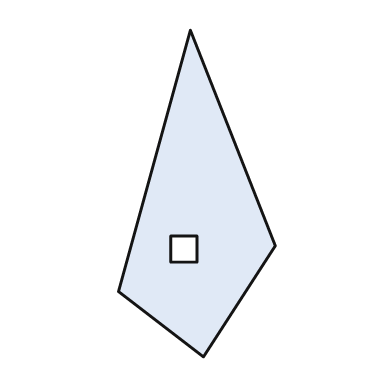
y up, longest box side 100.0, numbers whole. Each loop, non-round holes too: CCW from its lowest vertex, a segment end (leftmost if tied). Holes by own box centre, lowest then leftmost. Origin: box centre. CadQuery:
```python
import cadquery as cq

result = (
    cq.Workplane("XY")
    .moveTo(2.0, -50.0)
    .lineTo(24.0, -16.0)
    .lineTo(-2.0, 50.0)
    .lineTo(-24.0, -30.0)
    .close()
    .moveTo(-8.0, -21.0)
    .lineTo(0.0, -21.0)
    .lineTo(0.0, -13.0)
    .lineTo(-8.0, -13.0)
    .close()
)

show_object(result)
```